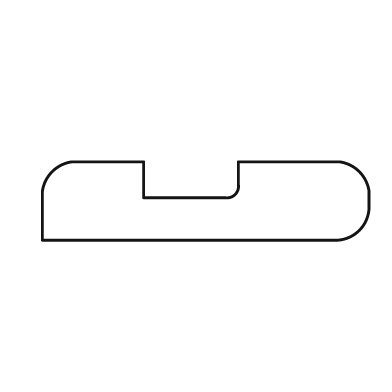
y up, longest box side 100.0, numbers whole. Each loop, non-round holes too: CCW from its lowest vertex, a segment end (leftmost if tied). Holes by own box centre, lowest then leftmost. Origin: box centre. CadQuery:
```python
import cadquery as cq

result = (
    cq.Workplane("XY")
    .moveTo(-50.0, -12.0)
    .lineTo(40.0, -12.0)
    .threePointArc((47.0, -9.0), (50.0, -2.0))
    .lineTo(50.0, 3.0)
    .threePointArc((47.0, 9.0), (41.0, 12.0))
    .lineTo(10.0, 12.0)
    .lineTo(10.0, 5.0)
    .threePointArc((9.0, 2.0), (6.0, 1.0))
    .lineTo(-19.0, 1.0)
    .lineTo(-19.0, 12.0)
    .lineTo(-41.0, 12.0)
    .threePointArc((-47.0, 9.0), (-50.0, 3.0))
    .close()
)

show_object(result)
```